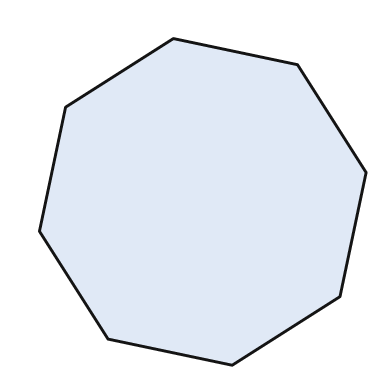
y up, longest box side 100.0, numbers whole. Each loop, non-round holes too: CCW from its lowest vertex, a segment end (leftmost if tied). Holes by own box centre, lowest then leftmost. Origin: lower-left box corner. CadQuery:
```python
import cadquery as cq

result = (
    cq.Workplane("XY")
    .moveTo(59.0, 0.0)
    .lineTo(92.0, 21.0)
    .lineTo(100.0, 59.0)
    .lineTo(79.0, 92.0)
    .lineTo(41.0, 100.0)
    .lineTo(8.0, 79.0)
    .lineTo(0.0, 41.0)
    .lineTo(21.0, 8.0)
    .close()
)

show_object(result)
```